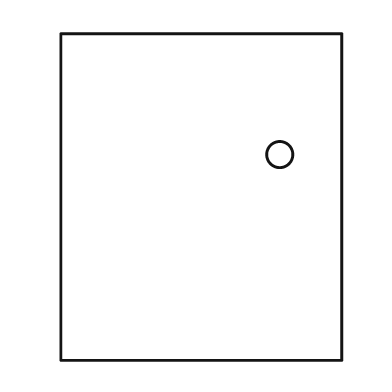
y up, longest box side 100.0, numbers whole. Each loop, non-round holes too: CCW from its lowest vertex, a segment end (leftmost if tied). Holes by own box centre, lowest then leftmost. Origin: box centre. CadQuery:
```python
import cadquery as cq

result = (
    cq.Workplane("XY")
    .moveTo(-43.0, -50.0)
    .lineTo(43.0, -50.0)
    .lineTo(43.0, 50.0)
    .lineTo(-43.0, 50.0)
    .close()
    .moveTo(24.0, 13.0)
    .circle(4.0)
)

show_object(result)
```